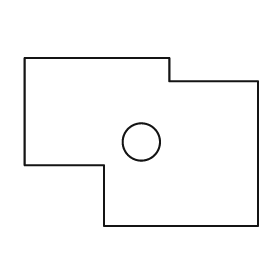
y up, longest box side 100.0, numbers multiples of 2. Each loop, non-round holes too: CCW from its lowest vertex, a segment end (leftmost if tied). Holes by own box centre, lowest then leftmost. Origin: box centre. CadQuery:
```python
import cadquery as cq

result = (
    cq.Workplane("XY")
    .moveTo(-16.0, -36.0)
    .lineTo(50.0, -36.0)
    .lineTo(50.0, 26.0)
    .lineTo(12.0, 26.0)
    .lineTo(12.0, 36.0)
    .lineTo(-50.0, 36.0)
    .lineTo(-50.0, -10.0)
    .lineTo(-16.0, -10.0)
    .close()
    .moveTo(0.0, 0.0)
    .circle(8.0)
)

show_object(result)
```